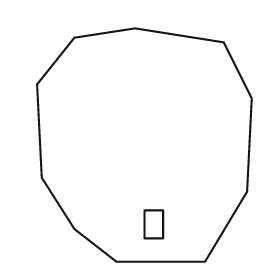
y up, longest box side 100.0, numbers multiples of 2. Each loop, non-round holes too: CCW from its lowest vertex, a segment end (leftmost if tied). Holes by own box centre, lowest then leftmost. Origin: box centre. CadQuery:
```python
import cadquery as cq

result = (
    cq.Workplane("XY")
    .moveTo(-12.0, -50.0)
    .lineTo(26.0, -50.0)
    .lineTo(44.0, -20.0)
    .lineTo(46.0, 20.0)
    .lineTo(34.0, 44.0)
    .lineTo(-4.0, 50.0)
    .lineTo(-30.0, 46.0)
    .lineTo(-46.0, 26.0)
    .lineTo(-44.0, -14.0)
    .lineTo(-30.0, -36.0)
    .close()
    .moveTo(0.0, -40.0)
    .lineTo(8.0, -40.0)
    .lineTo(8.0, -28.0)
    .lineTo(0.0, -28.0)
    .close()
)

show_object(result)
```